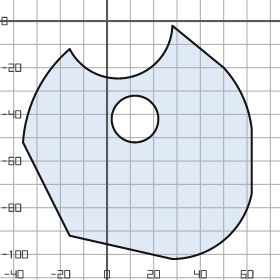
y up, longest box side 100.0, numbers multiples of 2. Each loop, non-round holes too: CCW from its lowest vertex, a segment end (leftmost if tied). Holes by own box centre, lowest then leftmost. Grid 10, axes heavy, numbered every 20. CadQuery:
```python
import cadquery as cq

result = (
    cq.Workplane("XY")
    .moveTo(28.0, -102.0)
    .threePointArc((50.0, -94.0), (62.0, -74.0))
    .lineTo(62.0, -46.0)
    .threePointArc((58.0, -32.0), (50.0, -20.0))
    .lineTo(28.0, -2.0)
    .threePointArc((10.0, -24.0), (-16.0, -12.0))
    .threePointArc((-30.0, -30.0), (-36.0, -52.0))
    .lineTo(-16.0, -92.0)
    .close()
    .moveTo(12.0, -42.0)
    .circle(10.0)
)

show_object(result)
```